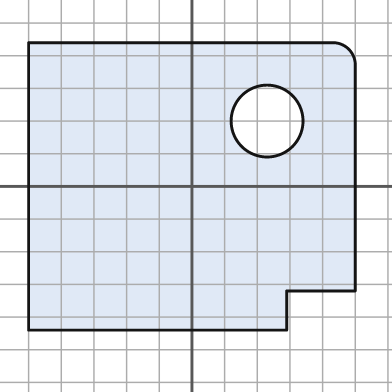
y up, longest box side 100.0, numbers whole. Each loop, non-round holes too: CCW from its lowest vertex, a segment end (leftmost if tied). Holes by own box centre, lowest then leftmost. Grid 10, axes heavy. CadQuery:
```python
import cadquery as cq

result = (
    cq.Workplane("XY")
    .moveTo(-50.0, -44.0)
    .lineTo(29.0, -44.0)
    .lineTo(29.0, -32.0)
    .lineTo(50.0, -32.0)
    .lineTo(50.0, 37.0)
    .threePointArc((48.0, 42.0), (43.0, 44.0))
    .lineTo(-50.0, 44.0)
    .close()
    .moveTo(23.0, 20.0)
    .circle(11.0)
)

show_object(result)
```